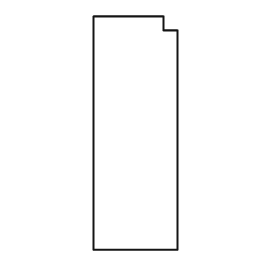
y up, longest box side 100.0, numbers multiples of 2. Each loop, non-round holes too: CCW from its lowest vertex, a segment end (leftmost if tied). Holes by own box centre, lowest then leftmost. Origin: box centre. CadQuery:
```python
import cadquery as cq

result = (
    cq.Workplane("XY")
    .moveTo(-18.0, -50.0)
    .lineTo(18.0, -50.0)
    .lineTo(18.0, 44.0)
    .lineTo(12.0, 44.0)
    .lineTo(12.0, 50.0)
    .lineTo(-18.0, 50.0)
    .close()
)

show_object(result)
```